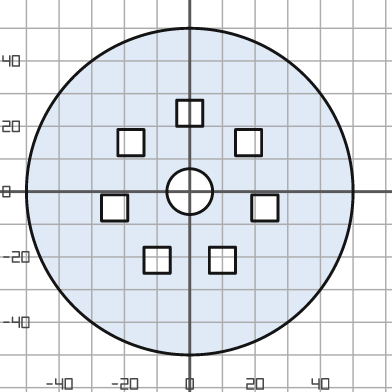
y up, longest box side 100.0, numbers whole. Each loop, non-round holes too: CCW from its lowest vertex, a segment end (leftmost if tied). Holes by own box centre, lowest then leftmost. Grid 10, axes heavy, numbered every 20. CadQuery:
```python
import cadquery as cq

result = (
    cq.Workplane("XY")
    .moveTo(0.0, 0.0)
    .circle(50.0)
    .moveTo(-14.0, -25.0)
    .lineTo(-6.0, -25.0)
    .lineTo(-6.0, -17.0)
    .lineTo(-14.0, -17.0)
    .close()
    .moveTo(6.0, -25.0)
    .lineTo(14.0, -25.0)
    .lineTo(14.0, -17.0)
    .lineTo(6.0, -17.0)
    .close()
    .moveTo(-27.0, -9.0)
    .lineTo(-19.0, -9.0)
    .lineTo(-19.0, -1.0)
    .lineTo(-27.0, -1.0)
    .close()
    .moveTo(19.0, -9.0)
    .lineTo(27.0, -9.0)
    .lineTo(27.0, -1.0)
    .lineTo(19.0, -1.0)
    .close()
    .moveTo(0.0, 0.0)
    .circle(7.0)
    .moveTo(-22.0, 11.0)
    .lineTo(-14.0, 11.0)
    .lineTo(-14.0, 19.0)
    .lineTo(-22.0, 19.0)
    .close()
    .moveTo(14.0, 11.0)
    .lineTo(22.0, 11.0)
    .lineTo(22.0, 19.0)
    .lineTo(14.0, 19.0)
    .close()
    .moveTo(-4.0, 20.0)
    .lineTo(4.0, 20.0)
    .lineTo(4.0, 28.0)
    .lineTo(-4.0, 28.0)
    .close()
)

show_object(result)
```